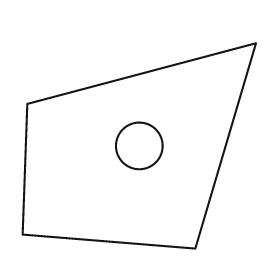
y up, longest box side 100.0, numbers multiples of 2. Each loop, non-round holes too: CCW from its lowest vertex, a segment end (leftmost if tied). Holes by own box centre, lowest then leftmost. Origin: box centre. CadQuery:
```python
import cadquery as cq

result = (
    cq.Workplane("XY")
    .moveTo(24.0, -44.0)
    .lineTo(50.0, 44.0)
    .lineTo(-48.0, 18.0)
    .lineTo(-50.0, -38.0)
    .close()
    .moveTo(0.0, 0.0)
    .circle(10.0)
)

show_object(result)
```